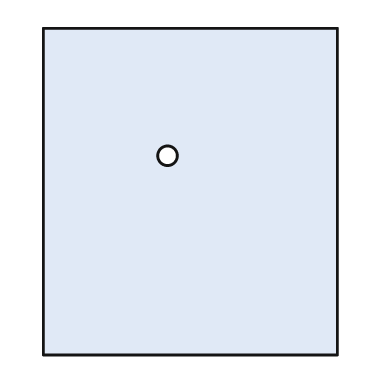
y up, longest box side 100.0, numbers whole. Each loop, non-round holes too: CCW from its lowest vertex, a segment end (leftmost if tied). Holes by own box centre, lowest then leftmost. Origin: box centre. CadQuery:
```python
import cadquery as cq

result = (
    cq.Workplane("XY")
    .moveTo(-45.0, -50.0)
    .lineTo(45.0, -50.0)
    .lineTo(45.0, 50.0)
    .lineTo(-45.0, 50.0)
    .close()
    .moveTo(-7.0, 11.0)
    .circle(3.0)
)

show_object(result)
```